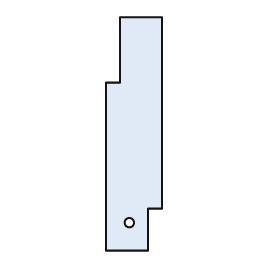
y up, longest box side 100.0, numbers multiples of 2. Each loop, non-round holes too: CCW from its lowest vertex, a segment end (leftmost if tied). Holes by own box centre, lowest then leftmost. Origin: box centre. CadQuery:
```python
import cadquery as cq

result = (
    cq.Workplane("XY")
    .moveTo(-12.0, -50.0)
    .lineTo(6.0, -50.0)
    .lineTo(6.0, -32.0)
    .lineTo(12.0, -32.0)
    .lineTo(12.0, 50.0)
    .lineTo(-6.0, 50.0)
    .lineTo(-6.0, 22.0)
    .lineTo(-12.0, 22.0)
    .close()
    .moveTo(-2.0, -38.0)
    .circle(2.0)
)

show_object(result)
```